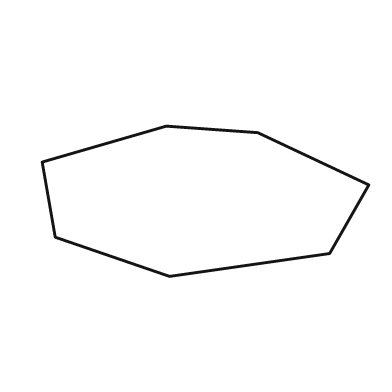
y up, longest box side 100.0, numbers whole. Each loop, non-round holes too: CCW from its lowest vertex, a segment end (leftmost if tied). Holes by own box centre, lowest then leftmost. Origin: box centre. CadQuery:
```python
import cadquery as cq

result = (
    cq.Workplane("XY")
    .moveTo(-11.0, -23.0)
    .lineTo(38.0, -16.0)
    .lineTo(50.0, 5.0)
    .lineTo(16.0, 21.0)
    .lineTo(-12.0, 23.0)
    .lineTo(-50.0, 12.0)
    .lineTo(-46.0, -11.0)
    .close()
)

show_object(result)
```